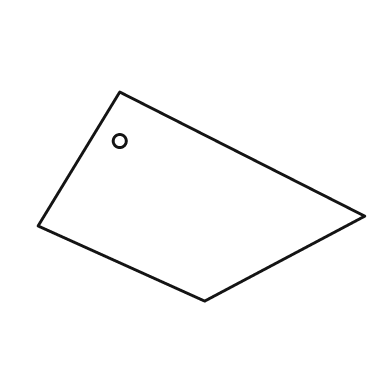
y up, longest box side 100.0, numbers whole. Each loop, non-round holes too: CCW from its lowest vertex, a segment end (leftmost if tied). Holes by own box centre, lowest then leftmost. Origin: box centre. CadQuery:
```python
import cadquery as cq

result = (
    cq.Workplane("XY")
    .moveTo(1.0, -32.0)
    .lineTo(50.0, -6.0)
    .lineTo(-25.0, 32.0)
    .lineTo(-50.0, -9.0)
    .close()
    .moveTo(-25.0, 17.0)
    .circle(2.0)
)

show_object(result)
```